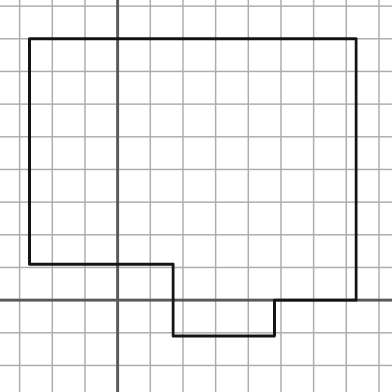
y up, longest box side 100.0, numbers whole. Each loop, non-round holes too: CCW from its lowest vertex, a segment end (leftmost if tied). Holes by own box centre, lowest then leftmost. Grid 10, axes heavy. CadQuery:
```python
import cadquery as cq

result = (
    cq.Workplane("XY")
    .moveTo(17.0, -11.0)
    .lineTo(48.0, -11.0)
    .lineTo(48.0, 0.0)
    .lineTo(73.0, 0.0)
    .lineTo(73.0, 80.0)
    .lineTo(-27.0, 80.0)
    .lineTo(-27.0, 11.0)
    .lineTo(17.0, 11.0)
    .close()
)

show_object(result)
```